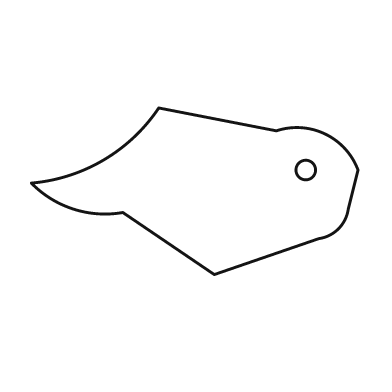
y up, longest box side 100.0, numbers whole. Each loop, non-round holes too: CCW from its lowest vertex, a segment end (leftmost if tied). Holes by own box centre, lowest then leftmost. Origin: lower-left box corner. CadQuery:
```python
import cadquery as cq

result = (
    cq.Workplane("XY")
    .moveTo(56.0, 0.0)
    .lineTo(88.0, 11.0)
    .threePointArc((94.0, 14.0), (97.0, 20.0))
    .lineTo(100.0, 32.0)
    .threePointArc((90.0, 43.0), (75.0, 44.0))
    .lineTo(39.0, 51.0)
    .threePointArc((22.0, 35.0), (0.0, 28.0))
    .threePointArc((13.0, 20.0), (28.0, 19.0))
    .close()
    .moveTo(84.0, 32.0)
    .circle(3.0)
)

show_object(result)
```